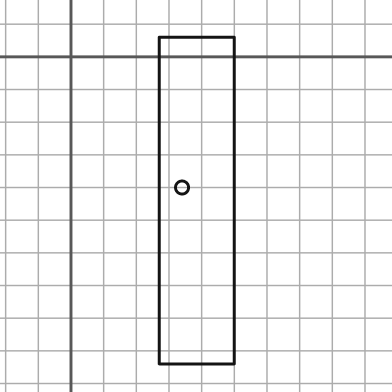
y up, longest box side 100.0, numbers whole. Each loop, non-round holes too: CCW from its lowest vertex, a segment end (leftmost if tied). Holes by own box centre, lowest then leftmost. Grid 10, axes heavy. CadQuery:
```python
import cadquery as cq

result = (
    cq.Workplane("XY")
    .moveTo(27.0, -94.0)
    .lineTo(50.0, -94.0)
    .lineTo(50.0, 6.0)
    .lineTo(27.0, 6.0)
    .close()
    .moveTo(34.0, -40.0)
    .circle(2.0)
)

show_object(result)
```